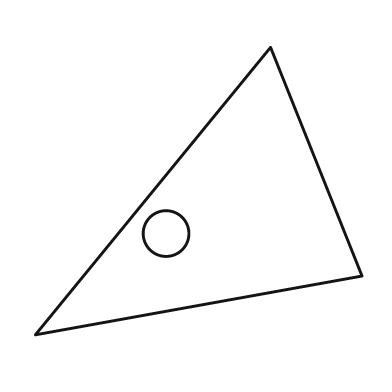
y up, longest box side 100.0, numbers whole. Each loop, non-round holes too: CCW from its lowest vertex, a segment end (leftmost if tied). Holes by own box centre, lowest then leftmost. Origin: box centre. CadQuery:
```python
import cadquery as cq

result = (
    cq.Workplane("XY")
    .moveTo(-50.0, -44.0)
    .lineTo(50.0, -26.0)
    .lineTo(22.0, 44.0)
    .close()
    .moveTo(-10.0, -13.0)
    .circle(7.0)
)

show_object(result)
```